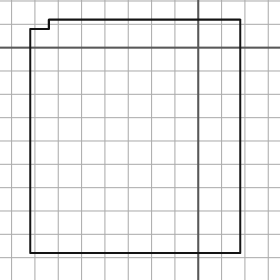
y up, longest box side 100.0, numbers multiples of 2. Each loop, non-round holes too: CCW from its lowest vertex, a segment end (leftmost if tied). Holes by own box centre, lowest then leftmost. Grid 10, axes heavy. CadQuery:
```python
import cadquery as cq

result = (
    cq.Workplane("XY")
    .moveTo(-72.0, -88.0)
    .lineTo(18.0, -88.0)
    .lineTo(18.0, 12.0)
    .lineTo(-64.0, 12.0)
    .lineTo(-64.0, 8.0)
    .lineTo(-72.0, 8.0)
    .close()
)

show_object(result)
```